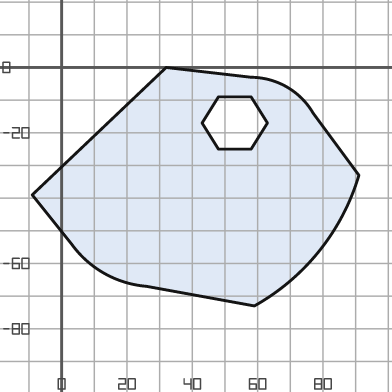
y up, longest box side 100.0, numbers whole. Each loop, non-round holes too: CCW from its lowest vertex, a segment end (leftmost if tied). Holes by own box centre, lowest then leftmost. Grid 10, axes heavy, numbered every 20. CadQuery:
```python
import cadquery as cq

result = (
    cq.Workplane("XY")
    .moveTo(59.0, -73.0)
    .threePointArc((79.0, -56.0), (91.0, -33.0))
    .lineTo(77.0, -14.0)
    .threePointArc((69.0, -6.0), (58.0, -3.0))
    .lineTo(32.0, 0.0)
    .lineTo(-9.0, -39.0)
    .lineTo(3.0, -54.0)
    .threePointArc((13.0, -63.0), (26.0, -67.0))
    .close()
    .moveTo(48.0, -25.0)
    .lineTo(58.0, -25.0)
    .lineTo(63.0, -17.0)
    .lineTo(58.0, -9.0)
    .lineTo(48.0, -9.0)
    .lineTo(43.0, -17.0)
    .close()
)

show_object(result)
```